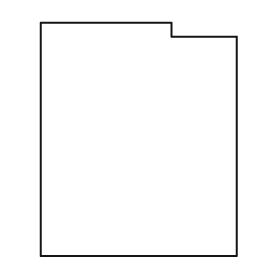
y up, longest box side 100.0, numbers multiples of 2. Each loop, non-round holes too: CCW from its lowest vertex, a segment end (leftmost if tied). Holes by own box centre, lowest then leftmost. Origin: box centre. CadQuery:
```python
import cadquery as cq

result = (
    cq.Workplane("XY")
    .moveTo(-42.0, -50.0)
    .lineTo(42.0, -50.0)
    .lineTo(42.0, 44.0)
    .lineTo(14.0, 44.0)
    .lineTo(14.0, 50.0)
    .lineTo(-42.0, 50.0)
    .close()
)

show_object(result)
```